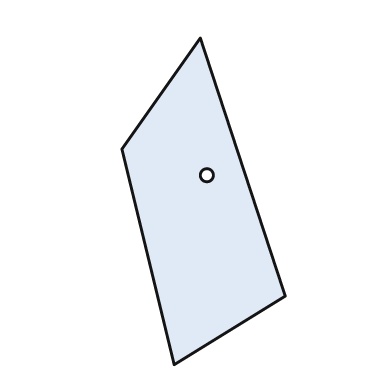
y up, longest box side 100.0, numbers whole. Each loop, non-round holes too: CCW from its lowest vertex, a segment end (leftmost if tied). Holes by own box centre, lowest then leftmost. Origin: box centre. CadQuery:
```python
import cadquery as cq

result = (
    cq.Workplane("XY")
    .moveTo(-9.0, -50.0)
    .lineTo(25.0, -29.0)
    .lineTo(-1.0, 50.0)
    .lineTo(-25.0, 16.0)
    .close()
    .moveTo(1.0, 8.0)
    .circle(2.0)
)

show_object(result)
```